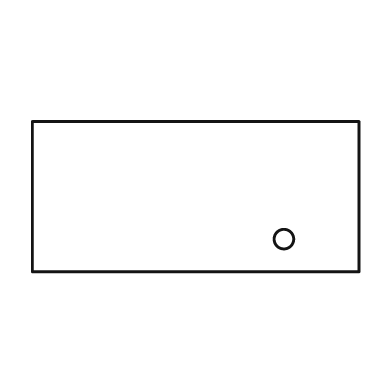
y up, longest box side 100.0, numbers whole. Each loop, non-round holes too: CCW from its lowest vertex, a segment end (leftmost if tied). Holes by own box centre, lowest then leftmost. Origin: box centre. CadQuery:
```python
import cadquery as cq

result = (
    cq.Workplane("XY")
    .moveTo(-50.0, -23.0)
    .lineTo(50.0, -23.0)
    .lineTo(50.0, 23.0)
    .lineTo(-50.0, 23.0)
    .close()
    .moveTo(27.0, -13.0)
    .circle(3.0)
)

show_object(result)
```